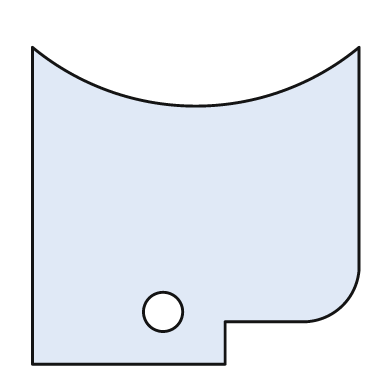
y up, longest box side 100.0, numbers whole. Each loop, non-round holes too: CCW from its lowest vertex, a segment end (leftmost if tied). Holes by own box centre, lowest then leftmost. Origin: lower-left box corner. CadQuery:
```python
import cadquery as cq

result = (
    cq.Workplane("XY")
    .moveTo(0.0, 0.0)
    .lineTo(59.0, 0.0)
    .lineTo(59.0, 13.0)
    .lineTo(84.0, 13.0)
    .threePointArc((95.0, 18.0), (100.0, 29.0))
    .lineTo(100.0, 97.0)
    .threePointArc((50.0, 79.0), (0.0, 97.0))
    .close()
    .moveTo(40.0, 16.0)
    .circle(6.0)
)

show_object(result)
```